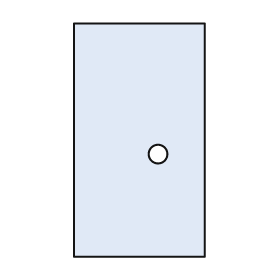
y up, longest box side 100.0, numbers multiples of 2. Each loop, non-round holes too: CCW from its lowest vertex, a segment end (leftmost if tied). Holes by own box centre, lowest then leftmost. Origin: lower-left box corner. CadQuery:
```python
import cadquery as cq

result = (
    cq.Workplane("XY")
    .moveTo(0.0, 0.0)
    .lineTo(56.0, 0.0)
    .lineTo(56.0, 100.0)
    .lineTo(0.0, 100.0)
    .close()
    .moveTo(36.0, 44.0)
    .circle(4.0)
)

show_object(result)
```